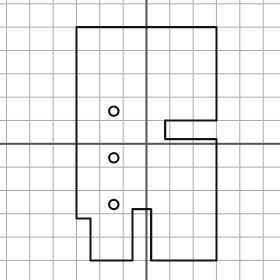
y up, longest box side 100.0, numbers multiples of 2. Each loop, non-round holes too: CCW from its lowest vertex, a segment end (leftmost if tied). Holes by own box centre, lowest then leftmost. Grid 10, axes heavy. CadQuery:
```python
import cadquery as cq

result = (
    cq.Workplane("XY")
    .moveTo(-24.0, -50.0)
    .lineTo(-6.0, -50.0)
    .lineTo(-6.0, -28.0)
    .lineTo(2.0, -28.0)
    .lineTo(2.0, -50.0)
    .lineTo(30.0, -50.0)
    .lineTo(30.0, 2.0)
    .lineTo(8.0, 2.0)
    .lineTo(8.0, 10.0)
    .lineTo(30.0, 10.0)
    .lineTo(30.0, 50.0)
    .lineTo(-30.0, 50.0)
    .lineTo(-30.0, -32.0)
    .lineTo(-24.0, -32.0)
    .close()
    .moveTo(-14.0, -26.0)
    .circle(2.0)
    .moveTo(-14.0, -6.0)
    .circle(2.0)
    .moveTo(-14.0, 14.0)
    .circle(2.0)
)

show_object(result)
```